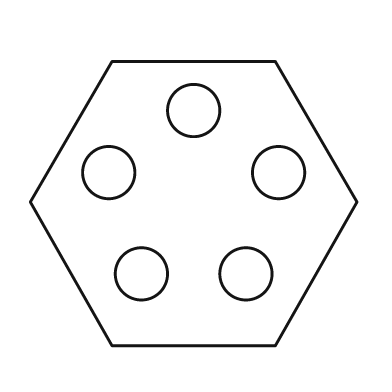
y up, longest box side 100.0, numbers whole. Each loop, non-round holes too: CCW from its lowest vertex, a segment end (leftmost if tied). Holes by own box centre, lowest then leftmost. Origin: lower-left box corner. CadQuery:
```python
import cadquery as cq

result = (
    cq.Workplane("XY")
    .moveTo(25.0, 0.0)
    .lineTo(75.0, 0.0)
    .lineTo(100.0, 44.0)
    .lineTo(75.0, 87.0)
    .lineTo(25.0, 87.0)
    .lineTo(0.0, 44.0)
    .close()
    .moveTo(34.0, 22.0)
    .circle(8.0)
    .moveTo(66.0, 22.0)
    .circle(8.0)
    .moveTo(24.0, 53.0)
    .circle(8.0)
    .moveTo(76.0, 53.0)
    .circle(8.0)
    .moveTo(50.0, 72.0)
    .circle(8.0)
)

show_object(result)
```